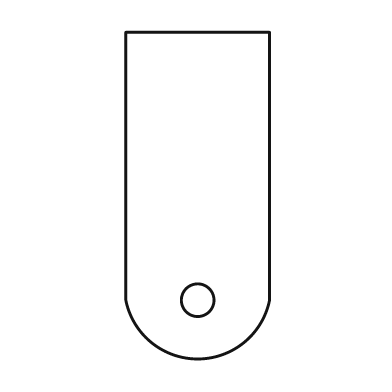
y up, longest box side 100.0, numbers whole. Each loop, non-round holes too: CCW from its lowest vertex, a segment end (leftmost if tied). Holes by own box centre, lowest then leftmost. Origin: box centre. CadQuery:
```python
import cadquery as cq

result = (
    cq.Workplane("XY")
    .moveTo(-22.0, -32.0)
    .threePointArc((0.0, -50.0), (22.0, -32.0))
    .lineTo(22.0, 50.0)
    .lineTo(-22.0, 50.0)
    .close()
    .moveTo(0.0, -32.0)
    .circle(5.0)
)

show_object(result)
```